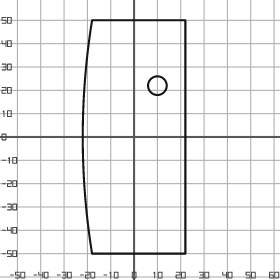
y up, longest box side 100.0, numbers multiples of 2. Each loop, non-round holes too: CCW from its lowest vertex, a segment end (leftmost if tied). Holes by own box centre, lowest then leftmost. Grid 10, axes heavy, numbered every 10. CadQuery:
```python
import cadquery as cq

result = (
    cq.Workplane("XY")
    .moveTo(-18.0, -50.0)
    .lineTo(22.0, -50.0)
    .lineTo(22.0, 50.0)
    .lineTo(-18.0, 50.0)
    .threePointArc((-22.0, 0.0), (-18.0, -50.0))
    .close()
    .moveTo(10.0, 22.0)
    .circle(4.0)
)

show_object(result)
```